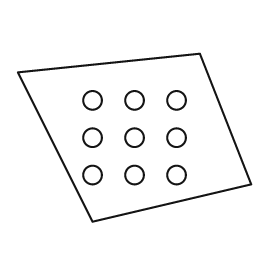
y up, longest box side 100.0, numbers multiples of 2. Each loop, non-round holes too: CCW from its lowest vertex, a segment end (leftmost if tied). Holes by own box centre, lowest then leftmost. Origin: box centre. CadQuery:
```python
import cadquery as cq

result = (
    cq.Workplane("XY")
    .moveTo(-18.0, -36.0)
    .lineTo(50.0, -20.0)
    .lineTo(28.0, 36.0)
    .lineTo(-50.0, 28.0)
    .close()
    .moveTo(-18.0, -16.0)
    .circle(4.0)
    .moveTo(0.0, -16.0)
    .circle(4.0)
    .moveTo(18.0, -16.0)
    .circle(4.0)
    .moveTo(-18.0, 0.0)
    .circle(4.0)
    .moveTo(0.0, 0.0)
    .circle(4.0)
    .moveTo(18.0, 0.0)
    .circle(4.0)
    .moveTo(-18.0, 16.0)
    .circle(4.0)
    .moveTo(0.0, 16.0)
    .circle(4.0)
    .moveTo(18.0, 16.0)
    .circle(4.0)
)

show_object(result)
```